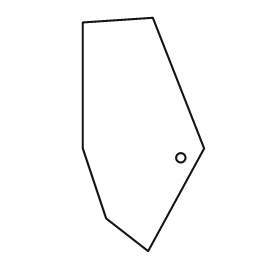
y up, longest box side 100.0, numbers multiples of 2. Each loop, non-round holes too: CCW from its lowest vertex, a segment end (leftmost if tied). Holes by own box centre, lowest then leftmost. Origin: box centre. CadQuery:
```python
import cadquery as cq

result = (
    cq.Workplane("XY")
    .moveTo(2.0, -50.0)
    .lineTo(26.0, -6.0)
    .lineTo(4.0, 50.0)
    .lineTo(-26.0, 48.0)
    .lineTo(-26.0, -6.0)
    .lineTo(-16.0, -36.0)
    .close()
    .moveTo(16.0, -10.0)
    .circle(2.0)
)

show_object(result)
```